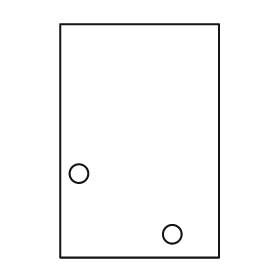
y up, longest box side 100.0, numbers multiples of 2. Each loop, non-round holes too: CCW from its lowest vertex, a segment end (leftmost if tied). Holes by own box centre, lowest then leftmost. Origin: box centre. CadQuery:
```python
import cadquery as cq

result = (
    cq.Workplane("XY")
    .moveTo(-34.0, -50.0)
    .lineTo(34.0, -50.0)
    .lineTo(34.0, 50.0)
    .lineTo(-34.0, 50.0)
    .close()
    .moveTo(14.0, -40.0)
    .circle(4.0)
    .moveTo(-26.0, -14.0)
    .circle(4.0)
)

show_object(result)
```